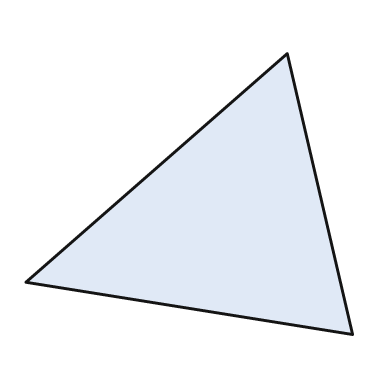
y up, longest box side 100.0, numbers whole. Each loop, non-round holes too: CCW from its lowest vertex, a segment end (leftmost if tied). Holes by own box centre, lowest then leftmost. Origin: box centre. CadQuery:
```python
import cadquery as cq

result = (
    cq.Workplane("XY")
    .moveTo(50.0, -43.0)
    .lineTo(30.0, 43.0)
    .lineTo(-50.0, -27.0)
    .close()
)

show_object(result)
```